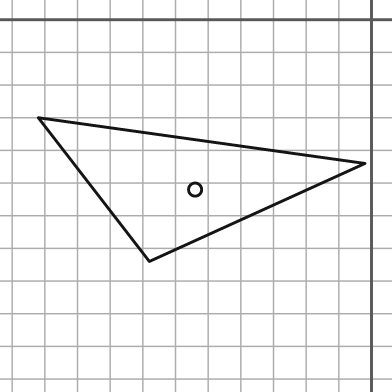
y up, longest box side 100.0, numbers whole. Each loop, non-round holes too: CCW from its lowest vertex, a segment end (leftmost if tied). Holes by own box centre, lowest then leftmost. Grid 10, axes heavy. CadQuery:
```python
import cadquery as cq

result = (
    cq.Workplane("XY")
    .moveTo(-68.0, -74.0)
    .lineTo(-2.0, -44.0)
    .lineTo(-102.0, -30.0)
    .close()
    .moveTo(-54.0, -52.0)
    .circle(2.0)
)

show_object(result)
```